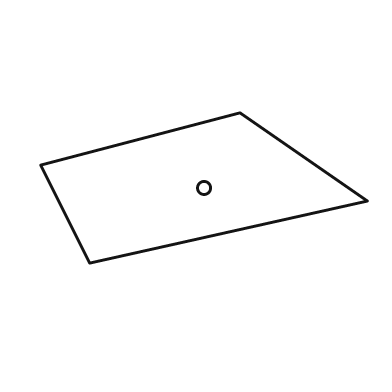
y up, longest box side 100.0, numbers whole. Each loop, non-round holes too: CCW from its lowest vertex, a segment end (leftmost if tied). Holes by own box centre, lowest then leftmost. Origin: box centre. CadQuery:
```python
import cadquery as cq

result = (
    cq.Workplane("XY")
    .moveTo(-35.0, -23.0)
    .lineTo(50.0, -4.0)
    .lineTo(11.0, 23.0)
    .lineTo(-50.0, 7.0)
    .close()
    .moveTo(0.0, 0.0)
    .circle(2.0)
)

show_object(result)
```